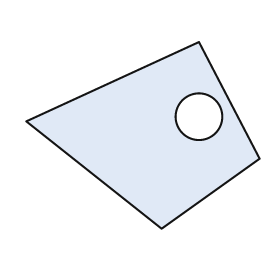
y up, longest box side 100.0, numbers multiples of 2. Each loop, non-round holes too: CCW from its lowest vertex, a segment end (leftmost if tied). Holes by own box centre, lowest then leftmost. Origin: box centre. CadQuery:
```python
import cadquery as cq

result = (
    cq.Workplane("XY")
    .moveTo(8.0, -40.0)
    .lineTo(50.0, -10.0)
    .lineTo(24.0, 40.0)
    .lineTo(-50.0, 6.0)
    .close()
    .moveTo(24.0, 8.0)
    .circle(10.0)
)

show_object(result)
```